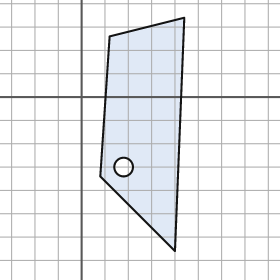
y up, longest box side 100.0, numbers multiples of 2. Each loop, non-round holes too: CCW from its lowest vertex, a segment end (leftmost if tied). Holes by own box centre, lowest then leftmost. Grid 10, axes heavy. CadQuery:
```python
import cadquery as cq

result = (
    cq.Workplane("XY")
    .moveTo(40.0, -66.0)
    .lineTo(44.0, 34.0)
    .lineTo(12.0, 26.0)
    .lineTo(8.0, -34.0)
    .close()
    .moveTo(18.0, -30.0)
    .circle(4.0)
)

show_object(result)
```